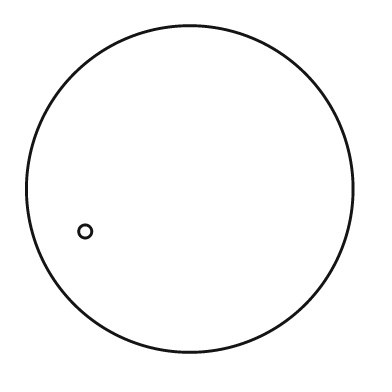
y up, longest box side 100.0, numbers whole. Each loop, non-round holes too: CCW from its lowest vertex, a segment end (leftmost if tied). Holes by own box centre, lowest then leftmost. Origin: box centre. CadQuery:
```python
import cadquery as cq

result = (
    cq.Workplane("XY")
    .moveTo(0.0, 0.0)
    .circle(50.0)
    .moveTo(-32.0, -13.0)
    .circle(2.0)
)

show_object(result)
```